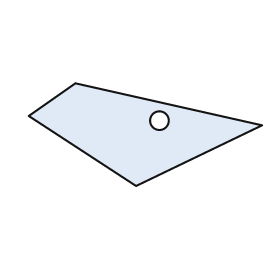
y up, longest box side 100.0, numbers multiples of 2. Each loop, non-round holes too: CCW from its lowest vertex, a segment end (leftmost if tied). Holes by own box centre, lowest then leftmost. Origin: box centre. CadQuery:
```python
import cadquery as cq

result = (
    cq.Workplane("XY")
    .moveTo(-4.0, -22.0)
    .lineTo(50.0, 4.0)
    .lineTo(-30.0, 22.0)
    .lineTo(-50.0, 8.0)
    .close()
    .moveTo(6.0, 6.0)
    .circle(4.0)
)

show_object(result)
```